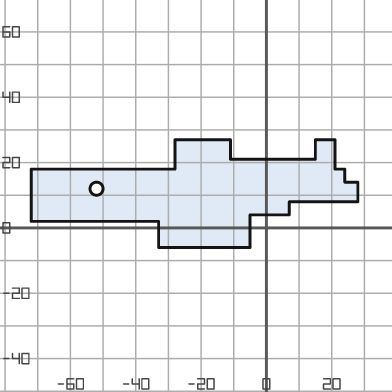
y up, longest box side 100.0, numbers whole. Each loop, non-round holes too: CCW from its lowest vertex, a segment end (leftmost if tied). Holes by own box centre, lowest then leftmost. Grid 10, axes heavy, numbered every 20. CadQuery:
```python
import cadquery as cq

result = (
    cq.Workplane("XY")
    .moveTo(-33.0, -6.0)
    .lineTo(-5.0, -6.0)
    .lineTo(-5.0, 4.0)
    .lineTo(7.0, 4.0)
    .lineTo(7.0, 8.0)
    .lineTo(28.0, 8.0)
    .lineTo(28.0, 14.0)
    .lineTo(24.0, 14.0)
    .lineTo(24.0, 18.0)
    .lineTo(21.0, 18.0)
    .lineTo(21.0, 27.0)
    .lineTo(15.0, 27.0)
    .lineTo(15.0, 21.0)
    .lineTo(-11.0, 21.0)
    .lineTo(-11.0, 27.0)
    .lineTo(-28.0, 27.0)
    .lineTo(-28.0, 18.0)
    .lineTo(-72.0, 18.0)
    .lineTo(-72.0, 2.0)
    .lineTo(-33.0, 2.0)
    .close()
    .moveTo(-52.0, 12.0)
    .circle(2.0)
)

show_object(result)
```